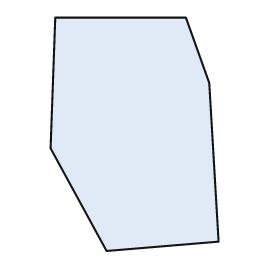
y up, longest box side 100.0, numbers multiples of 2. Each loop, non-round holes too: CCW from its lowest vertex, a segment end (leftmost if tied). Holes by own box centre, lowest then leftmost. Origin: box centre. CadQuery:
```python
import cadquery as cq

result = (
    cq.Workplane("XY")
    .moveTo(-12.0, -50.0)
    .lineTo(36.0, -46.0)
    .lineTo(32.0, 22.0)
    .lineTo(22.0, 50.0)
    .lineTo(-34.0, 50.0)
    .lineTo(-36.0, -6.0)
    .close()
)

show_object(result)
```